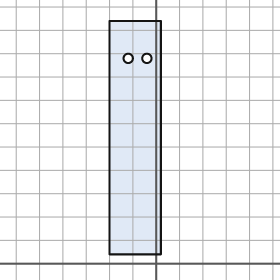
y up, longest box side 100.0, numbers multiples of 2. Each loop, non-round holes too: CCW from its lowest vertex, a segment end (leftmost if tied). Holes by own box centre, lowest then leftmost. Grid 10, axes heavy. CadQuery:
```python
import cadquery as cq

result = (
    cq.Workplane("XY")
    .moveTo(-20.0, 4.0)
    .lineTo(2.0, 4.0)
    .lineTo(2.0, 104.0)
    .lineTo(-20.0, 104.0)
    .close()
    .moveTo(-12.0, 88.0)
    .circle(2.0)
    .moveTo(-4.0, 88.0)
    .circle(2.0)
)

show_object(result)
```